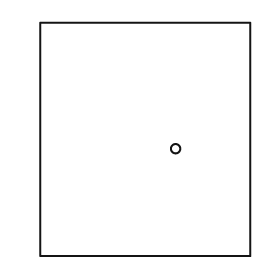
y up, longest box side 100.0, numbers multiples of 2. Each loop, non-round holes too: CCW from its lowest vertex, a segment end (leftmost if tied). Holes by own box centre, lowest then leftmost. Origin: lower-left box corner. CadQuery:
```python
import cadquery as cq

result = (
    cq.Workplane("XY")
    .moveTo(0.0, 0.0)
    .lineTo(90.0, 0.0)
    .lineTo(90.0, 100.0)
    .lineTo(0.0, 100.0)
    .close()
    .moveTo(58.0, 46.0)
    .circle(2.0)
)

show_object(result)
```